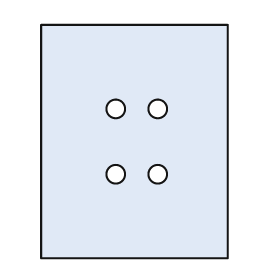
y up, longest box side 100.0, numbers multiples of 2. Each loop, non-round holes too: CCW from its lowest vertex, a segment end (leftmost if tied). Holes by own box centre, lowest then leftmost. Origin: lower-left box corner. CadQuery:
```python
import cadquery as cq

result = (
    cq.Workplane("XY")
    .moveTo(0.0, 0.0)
    .lineTo(80.0, 0.0)
    .lineTo(80.0, 100.0)
    .lineTo(0.0, 100.0)
    .close()
    .moveTo(32.0, 36.0)
    .circle(4.0)
    .moveTo(50.0, 36.0)
    .circle(4.0)
    .moveTo(32.0, 64.0)
    .circle(4.0)
    .moveTo(50.0, 64.0)
    .circle(4.0)
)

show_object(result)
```